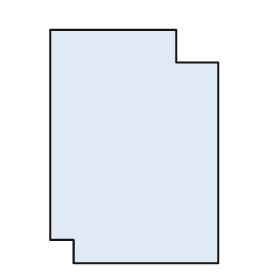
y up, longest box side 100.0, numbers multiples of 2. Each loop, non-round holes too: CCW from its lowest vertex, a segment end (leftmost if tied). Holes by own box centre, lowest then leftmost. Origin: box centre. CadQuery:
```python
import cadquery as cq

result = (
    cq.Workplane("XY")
    .moveTo(-26.0, -50.0)
    .lineTo(36.0, -50.0)
    .lineTo(36.0, 36.0)
    .lineTo(18.0, 36.0)
    .lineTo(18.0, 50.0)
    .lineTo(-36.0, 50.0)
    .lineTo(-36.0, -40.0)
    .lineTo(-26.0, -40.0)
    .close()
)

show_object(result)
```